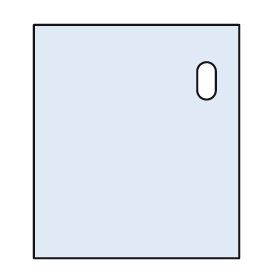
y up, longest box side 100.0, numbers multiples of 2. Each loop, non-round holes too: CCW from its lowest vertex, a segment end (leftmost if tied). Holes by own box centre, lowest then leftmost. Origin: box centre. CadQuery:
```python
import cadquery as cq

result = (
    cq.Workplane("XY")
    .moveTo(-44.0, -50.0)
    .lineTo(44.0, -50.0)
    .lineTo(44.0, 50.0)
    .lineTo(-44.0, 50.0)
    .close()
    .moveTo(26.0, 22.0)
    .threePointArc((30.0, 18.0), (34.0, 22.0))
    .lineTo(34.0, 30.0)
    .threePointArc((30.0, 34.0), (26.0, 30.0))
    .close()
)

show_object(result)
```